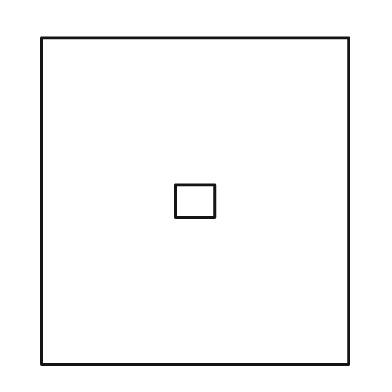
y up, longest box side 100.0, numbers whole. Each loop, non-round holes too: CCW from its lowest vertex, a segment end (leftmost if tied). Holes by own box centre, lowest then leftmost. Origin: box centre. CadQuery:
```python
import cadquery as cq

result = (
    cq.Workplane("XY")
    .moveTo(-47.0, -50.0)
    .lineTo(47.0, -50.0)
    .lineTo(47.0, 50.0)
    .lineTo(-47.0, 50.0)
    .close()
    .moveTo(-6.0, -5.0)
    .lineTo(6.0, -5.0)
    .lineTo(6.0, 5.0)
    .lineTo(-6.0, 5.0)
    .close()
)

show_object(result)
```